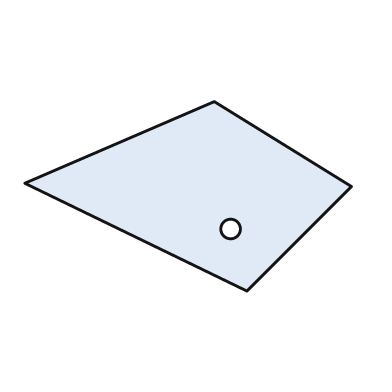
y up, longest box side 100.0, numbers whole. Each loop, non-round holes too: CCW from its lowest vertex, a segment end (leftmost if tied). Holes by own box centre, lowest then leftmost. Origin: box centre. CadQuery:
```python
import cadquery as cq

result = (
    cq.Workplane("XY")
    .moveTo(18.0, -29.0)
    .lineTo(50.0, 3.0)
    .lineTo(8.0, 29.0)
    .lineTo(-50.0, 4.0)
    .close()
    .moveTo(13.0, -10.0)
    .circle(3.0)
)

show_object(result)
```